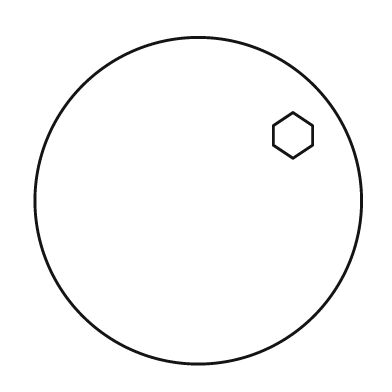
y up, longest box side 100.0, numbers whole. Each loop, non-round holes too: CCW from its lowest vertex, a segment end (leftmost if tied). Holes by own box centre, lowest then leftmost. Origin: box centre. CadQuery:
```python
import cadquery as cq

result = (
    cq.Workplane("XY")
    .moveTo(0.0, 0.0)
    .circle(50.0)
    .moveTo(29.0, 13.0)
    .lineTo(35.0, 17.0)
    .lineTo(35.0, 23.0)
    .lineTo(29.0, 27.0)
    .lineTo(23.0, 23.0)
    .lineTo(23.0, 17.0)
    .close()
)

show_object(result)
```